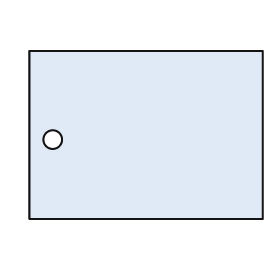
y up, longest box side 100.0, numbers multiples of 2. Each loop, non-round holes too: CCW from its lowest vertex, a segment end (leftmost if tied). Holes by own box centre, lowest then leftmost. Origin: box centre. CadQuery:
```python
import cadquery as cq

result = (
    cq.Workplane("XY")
    .moveTo(-50.0, -36.0)
    .lineTo(50.0, -36.0)
    .lineTo(50.0, 36.0)
    .lineTo(-50.0, 36.0)
    .close()
    .moveTo(-40.0, -2.0)
    .circle(4.0)
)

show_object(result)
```